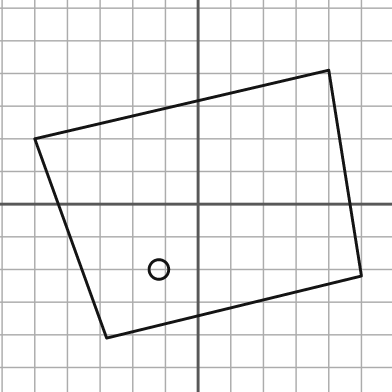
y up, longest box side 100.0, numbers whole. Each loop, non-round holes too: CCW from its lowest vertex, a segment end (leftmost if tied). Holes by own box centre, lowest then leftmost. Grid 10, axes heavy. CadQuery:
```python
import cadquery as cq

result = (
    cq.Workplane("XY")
    .moveTo(-28.0, -41.0)
    .lineTo(50.0, -22.0)
    .lineTo(40.0, 41.0)
    .lineTo(-50.0, 20.0)
    .close()
    .moveTo(-12.0, -20.0)
    .circle(3.0)
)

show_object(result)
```